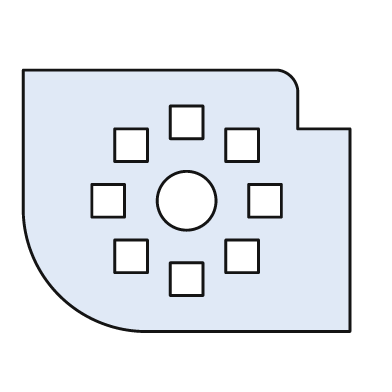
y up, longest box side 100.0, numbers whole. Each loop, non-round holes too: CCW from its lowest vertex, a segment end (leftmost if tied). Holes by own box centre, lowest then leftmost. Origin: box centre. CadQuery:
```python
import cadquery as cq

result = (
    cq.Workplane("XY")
    .moveTo(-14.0, -40.0)
    .lineTo(50.0, -40.0)
    .lineTo(50.0, 22.0)
    .lineTo(34.0, 22.0)
    .lineTo(34.0, 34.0)
    .threePointArc((32.0, 38.0), (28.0, 40.0))
    .lineTo(-50.0, 40.0)
    .lineTo(-50.0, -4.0)
    .threePointArc((-39.0, -29.0), (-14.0, -40.0))
    .close()
    .moveTo(-5.0, -29.0)
    .lineTo(5.0, -29.0)
    .lineTo(5.0, -19.0)
    .lineTo(-5.0, -19.0)
    .close()
    .moveTo(-22.0, -22.0)
    .lineTo(-12.0, -22.0)
    .lineTo(-12.0, -12.0)
    .lineTo(-22.0, -12.0)
    .close()
    .moveTo(12.0, -22.0)
    .lineTo(22.0, -22.0)
    .lineTo(22.0, -12.0)
    .lineTo(12.0, -12.0)
    .close()
    .moveTo(-29.0, -5.0)
    .lineTo(-19.0, -5.0)
    .lineTo(-19.0, 5.0)
    .lineTo(-29.0, 5.0)
    .close()
    .moveTo(0.0, 0.0)
    .circle(9.0)
    .moveTo(19.0, -5.0)
    .lineTo(29.0, -5.0)
    .lineTo(29.0, 5.0)
    .lineTo(19.0, 5.0)
    .close()
    .moveTo(-22.0, 12.0)
    .lineTo(-12.0, 12.0)
    .lineTo(-12.0, 22.0)
    .lineTo(-22.0, 22.0)
    .close()
    .moveTo(12.0, 12.0)
    .lineTo(22.0, 12.0)
    .lineTo(22.0, 22.0)
    .lineTo(12.0, 22.0)
    .close()
    .moveTo(-5.0, 19.0)
    .lineTo(5.0, 19.0)
    .lineTo(5.0, 29.0)
    .lineTo(-5.0, 29.0)
    .close()
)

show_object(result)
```